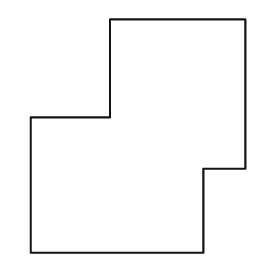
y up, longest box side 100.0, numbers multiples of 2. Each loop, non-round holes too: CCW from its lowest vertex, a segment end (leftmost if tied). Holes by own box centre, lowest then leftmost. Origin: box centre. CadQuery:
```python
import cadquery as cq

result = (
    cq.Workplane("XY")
    .moveTo(-46.0, -50.0)
    .lineTo(28.0, -50.0)
    .lineTo(28.0, -14.0)
    .lineTo(46.0, -14.0)
    .lineTo(46.0, 50.0)
    .lineTo(-12.0, 50.0)
    .lineTo(-12.0, 8.0)
    .lineTo(-46.0, 8.0)
    .close()
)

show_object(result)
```